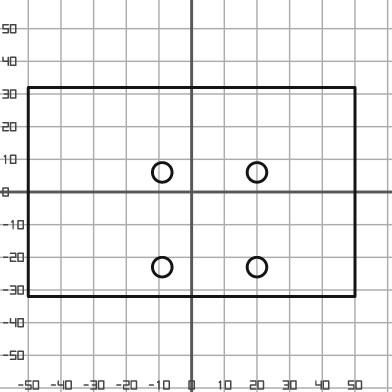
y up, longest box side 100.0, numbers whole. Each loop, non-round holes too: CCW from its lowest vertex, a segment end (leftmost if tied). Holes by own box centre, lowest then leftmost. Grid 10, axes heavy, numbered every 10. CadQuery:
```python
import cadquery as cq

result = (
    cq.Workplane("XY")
    .moveTo(-50.0, -32.0)
    .lineTo(50.0, -32.0)
    .lineTo(50.0, 32.0)
    .lineTo(-50.0, 32.0)
    .close()
    .moveTo(-9.0, -23.0)
    .circle(3.0)
    .moveTo(20.0, -23.0)
    .circle(3.0)
    .moveTo(-9.0, 6.0)
    .circle(3.0)
    .moveTo(20.0, 6.0)
    .circle(3.0)
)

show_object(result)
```